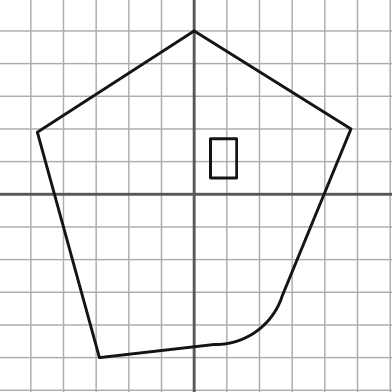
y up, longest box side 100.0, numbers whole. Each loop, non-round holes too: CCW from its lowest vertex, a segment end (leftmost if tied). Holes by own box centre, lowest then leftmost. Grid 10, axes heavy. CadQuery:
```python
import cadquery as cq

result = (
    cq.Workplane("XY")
    .moveTo(-29.0, -50.0)
    .lineTo(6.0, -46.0)
    .threePointArc((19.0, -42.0), (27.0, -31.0))
    .lineTo(48.0, 20.0)
    .lineTo(0.0, 50.0)
    .lineTo(-48.0, 19.0)
    .close()
    .moveTo(5.0, 5.0)
    .lineTo(13.0, 5.0)
    .lineTo(13.0, 17.0)
    .lineTo(5.0, 17.0)
    .close()
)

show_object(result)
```